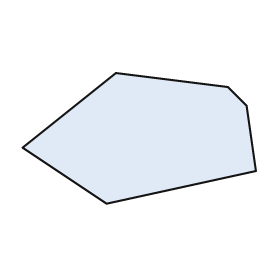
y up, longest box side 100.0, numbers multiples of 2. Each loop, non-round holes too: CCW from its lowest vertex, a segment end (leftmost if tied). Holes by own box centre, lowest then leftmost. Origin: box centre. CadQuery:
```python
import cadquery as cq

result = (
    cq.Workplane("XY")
    .moveTo(-14.0, -28.0)
    .lineTo(50.0, -14.0)
    .lineTo(46.0, 14.0)
    .lineTo(38.0, 22.0)
    .lineTo(-10.0, 28.0)
    .lineTo(-50.0, -4.0)
    .close()
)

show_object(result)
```